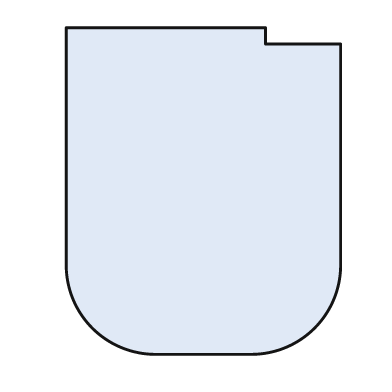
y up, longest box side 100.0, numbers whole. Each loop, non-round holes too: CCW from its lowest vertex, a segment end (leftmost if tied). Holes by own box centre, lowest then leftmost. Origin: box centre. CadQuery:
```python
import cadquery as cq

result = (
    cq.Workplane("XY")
    .moveTo(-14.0, -50.0)
    .lineTo(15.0, -50.0)
    .threePointArc((34.0, -42.0), (42.0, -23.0))
    .lineTo(42.0, 45.0)
    .lineTo(19.0, 45.0)
    .lineTo(19.0, 50.0)
    .lineTo(-42.0, 50.0)
    .lineTo(-42.0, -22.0)
    .threePointArc((-34.0, -42.0), (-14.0, -50.0))
    .close()
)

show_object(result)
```